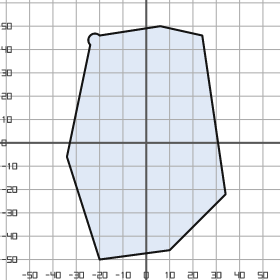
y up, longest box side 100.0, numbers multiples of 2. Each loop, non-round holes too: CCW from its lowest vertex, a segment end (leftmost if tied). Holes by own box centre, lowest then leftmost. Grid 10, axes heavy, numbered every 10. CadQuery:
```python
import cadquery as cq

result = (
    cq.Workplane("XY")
    .moveTo(-20.0, -50.0)
    .lineTo(10.0, -46.0)
    .lineTo(34.0, -22.0)
    .lineTo(24.0, 46.0)
    .lineTo(6.0, 50.0)
    .lineTo(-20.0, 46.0)
    .threePointArc((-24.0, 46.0), (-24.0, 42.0))
    .lineTo(-34.0, -6.0)
    .close()
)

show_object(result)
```